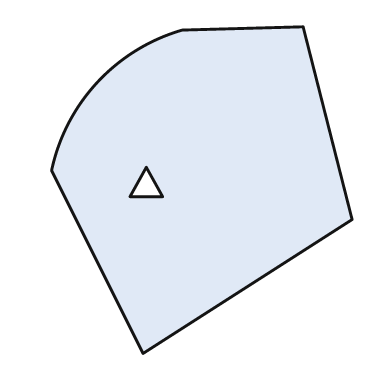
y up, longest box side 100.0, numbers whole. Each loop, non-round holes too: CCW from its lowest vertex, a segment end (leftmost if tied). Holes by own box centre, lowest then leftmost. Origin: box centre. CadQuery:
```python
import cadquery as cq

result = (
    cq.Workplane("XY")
    .moveTo(-18.0, -50.0)
    .lineTo(46.0, -9.0)
    .lineTo(31.0, 50.0)
    .lineTo(-6.0, 49.0)
    .threePointArc((-32.0, 33.0), (-46.0, 6.0))
    .close()
    .moveTo(-22.0, -2.0)
    .lineTo(-12.0, -2.0)
    .lineTo(-17.0, 7.0)
    .close()
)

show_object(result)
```